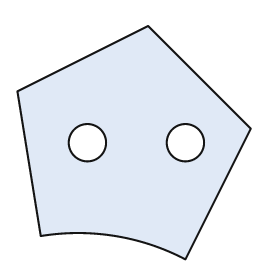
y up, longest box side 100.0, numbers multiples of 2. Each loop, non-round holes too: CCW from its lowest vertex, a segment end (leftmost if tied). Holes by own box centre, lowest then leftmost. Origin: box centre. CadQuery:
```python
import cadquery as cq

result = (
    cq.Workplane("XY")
    .moveTo(22.0, -50.0)
    .lineTo(50.0, 6.0)
    .lineTo(6.0, 50.0)
    .lineTo(-50.0, 22.0)
    .lineTo(-40.0, -40.0)
    .threePointArc((-8.0, -40.0), (22.0, -50.0))
    .close()
    .moveTo(-20.0, 0.0)
    .circle(8.0)
    .moveTo(22.0, 0.0)
    .circle(8.0)
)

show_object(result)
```